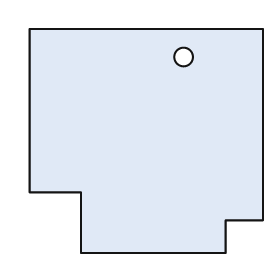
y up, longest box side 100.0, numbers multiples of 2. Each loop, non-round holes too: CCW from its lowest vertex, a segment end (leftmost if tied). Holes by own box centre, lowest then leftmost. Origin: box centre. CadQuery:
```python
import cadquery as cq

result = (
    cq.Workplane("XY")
    .moveTo(-28.0, -48.0)
    .lineTo(34.0, -48.0)
    .lineTo(34.0, -34.0)
    .lineTo(50.0, -34.0)
    .lineTo(50.0, 48.0)
    .lineTo(-50.0, 48.0)
    .lineTo(-50.0, -22.0)
    .lineTo(-28.0, -22.0)
    .close()
    .moveTo(16.0, 36.0)
    .circle(4.0)
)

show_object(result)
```